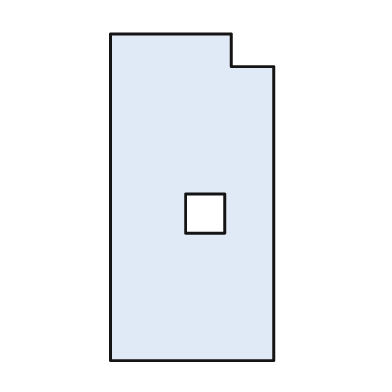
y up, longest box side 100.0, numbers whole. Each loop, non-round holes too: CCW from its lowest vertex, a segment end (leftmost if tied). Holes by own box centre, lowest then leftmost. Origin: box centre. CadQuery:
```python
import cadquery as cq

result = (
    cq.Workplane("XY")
    .moveTo(-25.0, -50.0)
    .lineTo(25.0, -50.0)
    .lineTo(25.0, 40.0)
    .lineTo(12.0, 40.0)
    .lineTo(12.0, 50.0)
    .lineTo(-25.0, 50.0)
    .close()
    .moveTo(-2.0, -11.0)
    .lineTo(10.0, -11.0)
    .lineTo(10.0, 1.0)
    .lineTo(-2.0, 1.0)
    .close()
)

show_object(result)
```